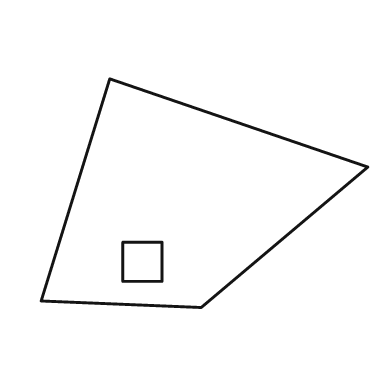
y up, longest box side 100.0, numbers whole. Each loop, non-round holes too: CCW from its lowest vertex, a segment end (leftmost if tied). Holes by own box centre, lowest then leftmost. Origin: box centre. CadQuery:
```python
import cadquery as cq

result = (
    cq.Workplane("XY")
    .moveTo(-1.0, -35.0)
    .lineTo(50.0, 8.0)
    .lineTo(-29.0, 35.0)
    .lineTo(-50.0, -33.0)
    .close()
    .moveTo(-25.0, -27.0)
    .lineTo(-13.0, -27.0)
    .lineTo(-13.0, -15.0)
    .lineTo(-25.0, -15.0)
    .close()
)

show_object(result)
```